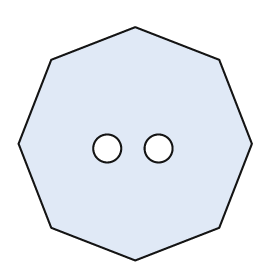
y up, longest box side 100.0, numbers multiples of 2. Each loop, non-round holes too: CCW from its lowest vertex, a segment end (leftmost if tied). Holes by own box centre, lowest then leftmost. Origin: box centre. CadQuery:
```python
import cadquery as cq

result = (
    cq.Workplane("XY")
    .moveTo(0.0, -50.0)
    .lineTo(36.0, -36.0)
    .lineTo(50.0, 0.0)
    .lineTo(36.0, 36.0)
    .lineTo(0.0, 50.0)
    .lineTo(-36.0, 36.0)
    .lineTo(-50.0, 0.0)
    .lineTo(-36.0, -36.0)
    .close()
    .moveTo(-12.0, -2.0)
    .circle(6.0)
    .moveTo(10.0, -2.0)
    .circle(6.0)
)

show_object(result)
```